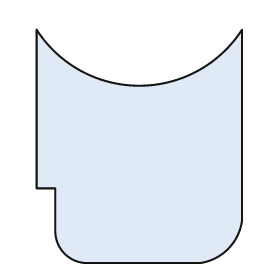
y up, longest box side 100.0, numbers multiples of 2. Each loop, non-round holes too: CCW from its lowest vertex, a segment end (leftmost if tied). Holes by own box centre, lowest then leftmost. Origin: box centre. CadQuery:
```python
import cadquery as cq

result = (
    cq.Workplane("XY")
    .moveTo(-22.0, -50.0)
    .lineTo(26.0, -50.0)
    .threePointArc((38.0, -44.0), (44.0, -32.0))
    .lineTo(44.0, 50.0)
    .threePointArc((0.0, 26.0), (-44.0, 50.0))
    .lineTo(-44.0, -18.0)
    .lineTo(-36.0, -18.0)
    .lineTo(-36.0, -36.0)
    .threePointArc((-32.0, -46.0), (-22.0, -50.0))
    .close()
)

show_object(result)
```